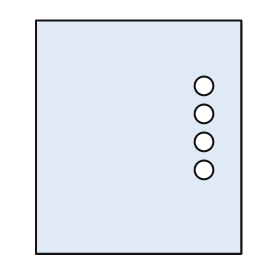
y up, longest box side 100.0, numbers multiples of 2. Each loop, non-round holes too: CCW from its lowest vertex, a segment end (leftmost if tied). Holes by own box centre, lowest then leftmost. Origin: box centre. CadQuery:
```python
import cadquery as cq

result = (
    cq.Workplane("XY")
    .moveTo(-44.0, -50.0)
    .lineTo(44.0, -50.0)
    .lineTo(44.0, 50.0)
    .lineTo(-44.0, 50.0)
    .close()
    .moveTo(28.0, -14.0)
    .circle(4.0)
    .moveTo(28.0, -2.0)
    .circle(4.0)
    .moveTo(28.0, 10.0)
    .circle(4.0)
    .moveTo(28.0, 22.0)
    .circle(4.0)
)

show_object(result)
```